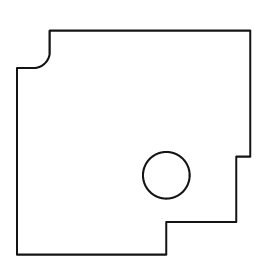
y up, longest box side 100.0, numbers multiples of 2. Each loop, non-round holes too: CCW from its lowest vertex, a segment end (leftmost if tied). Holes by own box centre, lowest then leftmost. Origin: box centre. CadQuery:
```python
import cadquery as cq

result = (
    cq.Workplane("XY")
    .moveTo(-50.0, -48.0)
    .lineTo(14.0, -48.0)
    .lineTo(14.0, -34.0)
    .lineTo(44.0, -34.0)
    .lineTo(44.0, -6.0)
    .lineTo(50.0, -6.0)
    .lineTo(50.0, 48.0)
    .lineTo(-36.0, 48.0)
    .lineTo(-36.0, 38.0)
    .threePointArc((-38.0, 34.0), (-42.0, 32.0))
    .lineTo(-50.0, 32.0)
    .close()
    .moveTo(14.0, -14.0)
    .circle(10.0)
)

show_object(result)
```